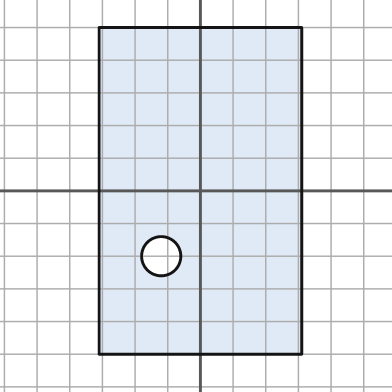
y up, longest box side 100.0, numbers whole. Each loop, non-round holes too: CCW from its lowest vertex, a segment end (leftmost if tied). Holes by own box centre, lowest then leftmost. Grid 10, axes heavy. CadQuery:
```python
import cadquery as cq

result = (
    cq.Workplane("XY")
    .moveTo(-31.0, -50.0)
    .lineTo(31.0, -50.0)
    .lineTo(31.0, 50.0)
    .lineTo(-31.0, 50.0)
    .close()
    .moveTo(-12.0, -20.0)
    .circle(6.0)
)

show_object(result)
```